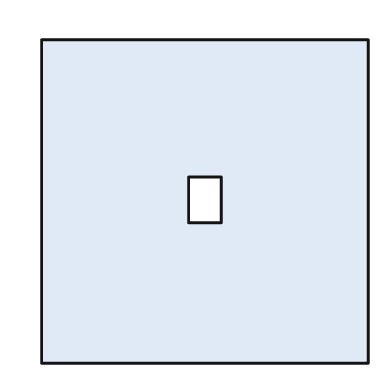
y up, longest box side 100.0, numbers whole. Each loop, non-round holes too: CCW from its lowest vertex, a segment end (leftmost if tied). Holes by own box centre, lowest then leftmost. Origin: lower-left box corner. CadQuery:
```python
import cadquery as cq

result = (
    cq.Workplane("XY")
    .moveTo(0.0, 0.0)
    .lineTo(100.0, 0.0)
    .lineTo(100.0, 99.0)
    .lineTo(0.0, 99.0)
    .close()
    .moveTo(45.0, 43.0)
    .lineTo(55.0, 43.0)
    .lineTo(55.0, 57.0)
    .lineTo(45.0, 57.0)
    .close()
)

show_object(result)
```